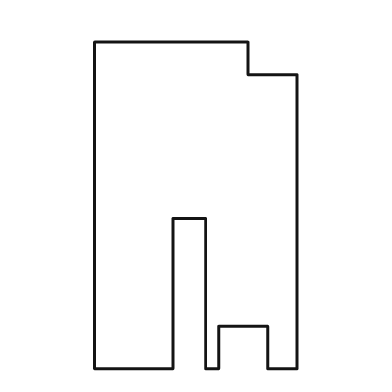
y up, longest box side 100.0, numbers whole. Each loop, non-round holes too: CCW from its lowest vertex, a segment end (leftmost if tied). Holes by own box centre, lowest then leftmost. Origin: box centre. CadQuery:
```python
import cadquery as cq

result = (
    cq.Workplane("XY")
    .moveTo(-31.0, -50.0)
    .lineTo(-7.0, -50.0)
    .lineTo(-7.0, -4.0)
    .lineTo(3.0, -4.0)
    .lineTo(3.0, -50.0)
    .lineTo(7.0, -50.0)
    .lineTo(7.0, -37.0)
    .lineTo(22.0, -37.0)
    .lineTo(22.0, -50.0)
    .lineTo(31.0, -50.0)
    .lineTo(31.0, 40.0)
    .lineTo(16.0, 40.0)
    .lineTo(16.0, 50.0)
    .lineTo(-31.0, 50.0)
    .close()
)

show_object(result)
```